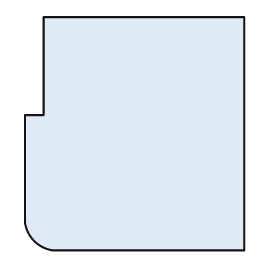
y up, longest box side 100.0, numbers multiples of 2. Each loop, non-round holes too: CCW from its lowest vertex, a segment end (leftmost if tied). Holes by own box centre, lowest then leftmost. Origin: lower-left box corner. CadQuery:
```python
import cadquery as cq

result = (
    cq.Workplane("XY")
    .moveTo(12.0, 0.0)
    .lineTo(94.0, 0.0)
    .lineTo(94.0, 100.0)
    .lineTo(8.0, 100.0)
    .lineTo(8.0, 58.0)
    .lineTo(0.0, 58.0)
    .lineTo(0.0, 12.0)
    .threePointArc((4.0, 4.0), (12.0, 0.0))
    .close()
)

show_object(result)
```